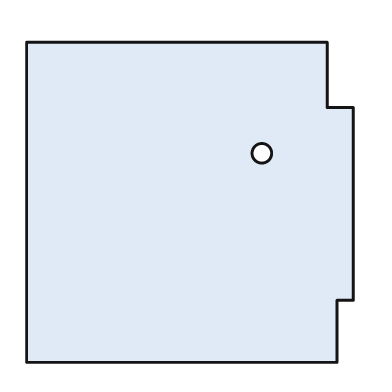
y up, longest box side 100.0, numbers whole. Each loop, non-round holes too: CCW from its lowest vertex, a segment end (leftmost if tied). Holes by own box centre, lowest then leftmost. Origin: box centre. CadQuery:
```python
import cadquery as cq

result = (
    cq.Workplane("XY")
    .moveTo(-50.0, -49.0)
    .lineTo(45.0, -49.0)
    .lineTo(45.0, -30.0)
    .lineTo(50.0, -30.0)
    .lineTo(50.0, 29.0)
    .lineTo(42.0, 29.0)
    .lineTo(42.0, 49.0)
    .lineTo(-50.0, 49.0)
    .close()
    .moveTo(22.0, 15.0)
    .circle(3.0)
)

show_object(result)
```